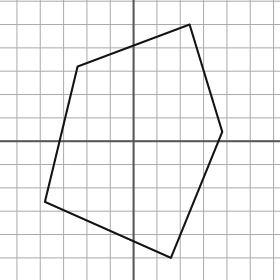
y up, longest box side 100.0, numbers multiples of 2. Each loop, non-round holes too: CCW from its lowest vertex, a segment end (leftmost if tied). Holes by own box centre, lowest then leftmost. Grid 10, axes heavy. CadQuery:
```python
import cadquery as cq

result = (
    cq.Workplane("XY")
    .moveTo(16.0, -50.0)
    .lineTo(38.0, 4.0)
    .lineTo(24.0, 50.0)
    .lineTo(-24.0, 32.0)
    .lineTo(-38.0, -26.0)
    .close()
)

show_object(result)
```